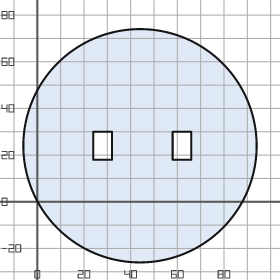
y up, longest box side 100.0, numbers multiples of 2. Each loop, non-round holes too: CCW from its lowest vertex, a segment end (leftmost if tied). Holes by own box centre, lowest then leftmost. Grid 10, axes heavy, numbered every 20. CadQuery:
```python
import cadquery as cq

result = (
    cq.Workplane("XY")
    .moveTo(44.0, 24.0)
    .circle(50.0)
    .moveTo(24.0, 18.0)
    .lineTo(32.0, 18.0)
    .lineTo(32.0, 30.0)
    .lineTo(24.0, 30.0)
    .close()
    .moveTo(58.0, 18.0)
    .lineTo(66.0, 18.0)
    .lineTo(66.0, 30.0)
    .lineTo(58.0, 30.0)
    .close()
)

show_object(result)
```